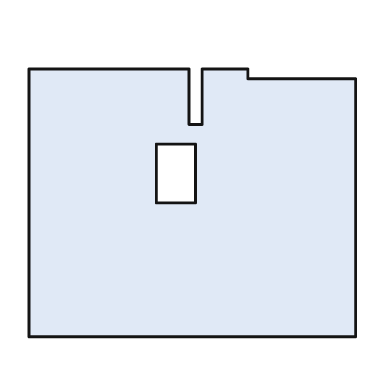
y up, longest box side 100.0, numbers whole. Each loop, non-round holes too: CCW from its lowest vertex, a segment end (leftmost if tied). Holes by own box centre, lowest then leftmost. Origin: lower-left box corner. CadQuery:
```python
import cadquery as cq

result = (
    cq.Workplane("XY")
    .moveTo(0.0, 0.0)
    .lineTo(100.0, 0.0)
    .lineTo(100.0, 79.0)
    .lineTo(67.0, 79.0)
    .lineTo(67.0, 82.0)
    .lineTo(53.0, 82.0)
    .lineTo(53.0, 65.0)
    .lineTo(49.0, 65.0)
    .lineTo(49.0, 82.0)
    .lineTo(0.0, 82.0)
    .close()
    .moveTo(39.0, 41.0)
    .lineTo(51.0, 41.0)
    .lineTo(51.0, 59.0)
    .lineTo(39.0, 59.0)
    .close()
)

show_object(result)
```